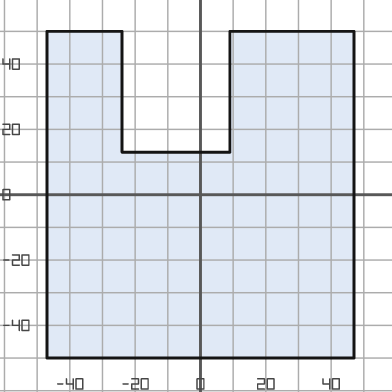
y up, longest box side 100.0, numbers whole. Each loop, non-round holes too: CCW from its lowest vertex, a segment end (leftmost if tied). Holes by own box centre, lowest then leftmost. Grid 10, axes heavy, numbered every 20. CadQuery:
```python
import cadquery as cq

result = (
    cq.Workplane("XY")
    .moveTo(-47.0, -50.0)
    .lineTo(47.0, -50.0)
    .lineTo(47.0, 50.0)
    .lineTo(9.0, 50.0)
    .lineTo(9.0, 13.0)
    .lineTo(-24.0, 13.0)
    .lineTo(-24.0, 50.0)
    .lineTo(-47.0, 50.0)
    .close()
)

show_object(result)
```